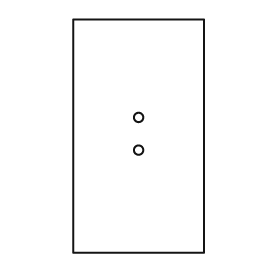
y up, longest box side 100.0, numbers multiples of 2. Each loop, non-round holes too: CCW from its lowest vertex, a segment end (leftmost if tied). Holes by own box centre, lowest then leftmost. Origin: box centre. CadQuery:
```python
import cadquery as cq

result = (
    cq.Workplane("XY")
    .moveTo(-28.0, -50.0)
    .lineTo(28.0, -50.0)
    .lineTo(28.0, 50.0)
    .lineTo(-28.0, 50.0)
    .close()
    .moveTo(0.0, -6.0)
    .circle(2.0)
    .moveTo(0.0, 8.0)
    .circle(2.0)
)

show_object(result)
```